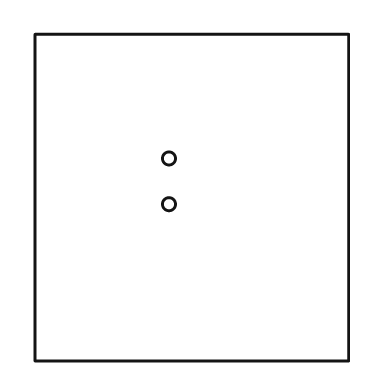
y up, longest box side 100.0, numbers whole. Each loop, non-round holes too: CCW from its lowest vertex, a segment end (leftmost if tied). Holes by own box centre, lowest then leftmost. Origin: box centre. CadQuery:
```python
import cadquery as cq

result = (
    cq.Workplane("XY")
    .moveTo(-48.0, -50.0)
    .lineTo(48.0, -50.0)
    .lineTo(48.0, 50.0)
    .lineTo(-48.0, 50.0)
    .close()
    .moveTo(-7.0, -2.0)
    .circle(2.0)
    .moveTo(-7.0, 12.0)
    .circle(2.0)
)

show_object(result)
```